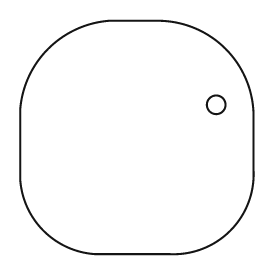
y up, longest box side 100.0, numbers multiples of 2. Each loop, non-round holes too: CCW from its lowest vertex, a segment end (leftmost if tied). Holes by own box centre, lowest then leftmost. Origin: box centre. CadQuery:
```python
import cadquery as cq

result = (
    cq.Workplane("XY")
    .moveTo(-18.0, -50.0)
    .lineTo(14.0, -50.0)
    .threePointArc((40.0, -40.0), (50.0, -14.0))
    .lineTo(50.0, 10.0)
    .threePointArc((38.0, 38.0), (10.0, 50.0))
    .lineTo(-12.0, 50.0)
    .threePointArc((-38.0, 38.0), (-50.0, 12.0))
    .lineTo(-50.0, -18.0)
    .threePointArc((-40.0, -40.0), (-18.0, -50.0))
    .close()
    .moveTo(34.0, 14.0)
    .circle(4.0)
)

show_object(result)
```